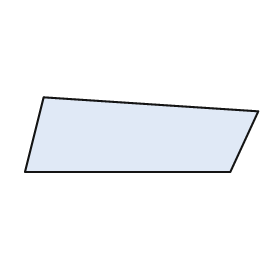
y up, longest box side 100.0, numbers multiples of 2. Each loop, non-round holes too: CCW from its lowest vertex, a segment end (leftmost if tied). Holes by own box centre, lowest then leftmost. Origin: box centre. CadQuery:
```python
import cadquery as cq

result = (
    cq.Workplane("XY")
    .moveTo(-50.0, -16.0)
    .lineTo(38.0, -16.0)
    .lineTo(50.0, 10.0)
    .lineTo(-42.0, 16.0)
    .close()
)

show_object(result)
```